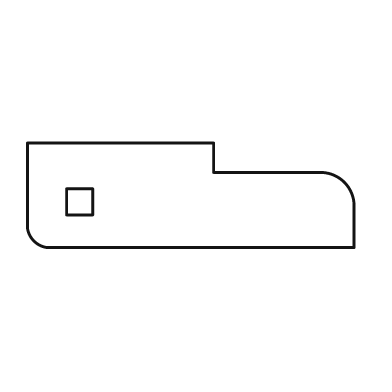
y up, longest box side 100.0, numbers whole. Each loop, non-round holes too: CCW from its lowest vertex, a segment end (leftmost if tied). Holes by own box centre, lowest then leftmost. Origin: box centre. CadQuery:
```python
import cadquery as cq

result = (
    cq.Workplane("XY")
    .moveTo(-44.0, -16.0)
    .lineTo(50.0, -16.0)
    .lineTo(50.0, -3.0)
    .threePointArc((47.0, 4.0), (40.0, 7.0))
    .lineTo(7.0, 7.0)
    .lineTo(7.0, 16.0)
    .lineTo(-50.0, 16.0)
    .lineTo(-50.0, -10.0)
    .threePointArc((-48.0, -14.0), (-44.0, -16.0))
    .close()
    .moveTo(-38.0, -6.0)
    .lineTo(-30.0, -6.0)
    .lineTo(-30.0, 2.0)
    .lineTo(-38.0, 2.0)
    .close()
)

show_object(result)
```